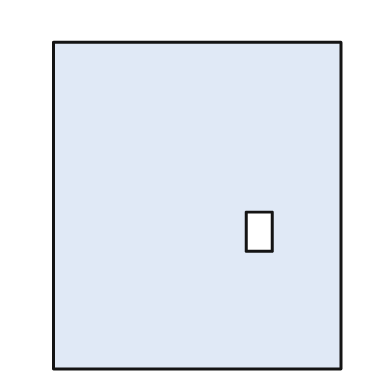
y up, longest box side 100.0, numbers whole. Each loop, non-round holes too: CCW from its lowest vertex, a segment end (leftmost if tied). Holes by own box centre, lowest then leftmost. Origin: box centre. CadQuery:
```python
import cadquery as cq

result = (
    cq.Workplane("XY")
    .moveTo(-44.0, -50.0)
    .lineTo(44.0, -50.0)
    .lineTo(44.0, 50.0)
    .lineTo(-44.0, 50.0)
    .close()
    .moveTo(15.0, -14.0)
    .lineTo(23.0, -14.0)
    .lineTo(23.0, -2.0)
    .lineTo(15.0, -2.0)
    .close()
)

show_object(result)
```